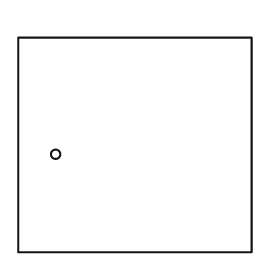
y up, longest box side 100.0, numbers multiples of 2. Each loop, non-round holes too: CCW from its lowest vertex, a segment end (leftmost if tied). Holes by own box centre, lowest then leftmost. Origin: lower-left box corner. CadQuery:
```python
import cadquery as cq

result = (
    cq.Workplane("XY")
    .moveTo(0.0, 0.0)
    .lineTo(100.0, 0.0)
    .lineTo(100.0, 92.0)
    .lineTo(0.0, 92.0)
    .close()
    .moveTo(16.0, 42.0)
    .circle(2.0)
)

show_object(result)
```